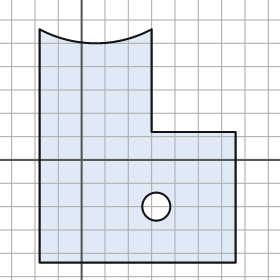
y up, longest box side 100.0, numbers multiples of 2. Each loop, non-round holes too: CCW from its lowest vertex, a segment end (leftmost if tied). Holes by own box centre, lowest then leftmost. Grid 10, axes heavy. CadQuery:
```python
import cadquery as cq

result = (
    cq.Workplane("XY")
    .moveTo(-18.0, -44.0)
    .lineTo(66.0, -44.0)
    .lineTo(66.0, 12.0)
    .lineTo(30.0, 12.0)
    .lineTo(30.0, 56.0)
    .threePointArc((6.0, 50.0), (-18.0, 56.0))
    .close()
    .moveTo(32.0, -20.0)
    .circle(6.0)
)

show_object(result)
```